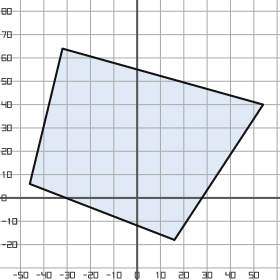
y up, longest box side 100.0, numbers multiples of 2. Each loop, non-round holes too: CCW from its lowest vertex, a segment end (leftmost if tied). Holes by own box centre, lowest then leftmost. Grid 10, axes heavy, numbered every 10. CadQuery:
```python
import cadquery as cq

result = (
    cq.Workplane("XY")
    .moveTo(16.0, -18.0)
    .lineTo(54.0, 40.0)
    .lineTo(-32.0, 64.0)
    .lineTo(-46.0, 6.0)
    .close()
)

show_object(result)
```